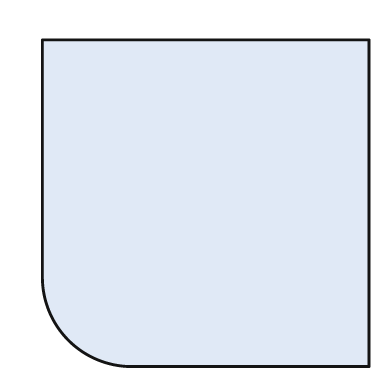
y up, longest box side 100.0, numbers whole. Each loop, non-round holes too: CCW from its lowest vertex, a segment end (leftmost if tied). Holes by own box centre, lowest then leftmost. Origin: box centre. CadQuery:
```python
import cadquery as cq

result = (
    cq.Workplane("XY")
    .moveTo(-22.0, -50.0)
    .lineTo(50.0, -50.0)
    .lineTo(50.0, 50.0)
    .lineTo(-50.0, 50.0)
    .lineTo(-50.0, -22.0)
    .threePointArc((-42.0, -42.0), (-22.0, -50.0))
    .close()
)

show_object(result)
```